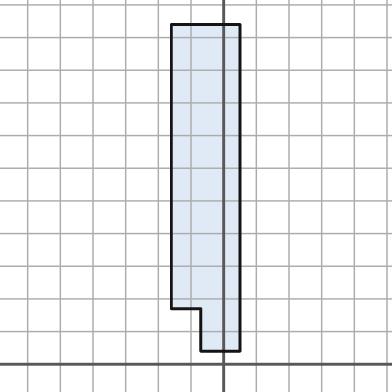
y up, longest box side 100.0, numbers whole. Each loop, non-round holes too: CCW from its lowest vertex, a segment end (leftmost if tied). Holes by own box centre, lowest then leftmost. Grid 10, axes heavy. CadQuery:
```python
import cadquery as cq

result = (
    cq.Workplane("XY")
    .moveTo(-7.0, 4.0)
    .lineTo(5.0, 4.0)
    .lineTo(5.0, 104.0)
    .lineTo(-16.0, 104.0)
    .lineTo(-16.0, 17.0)
    .lineTo(-7.0, 17.0)
    .close()
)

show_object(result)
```